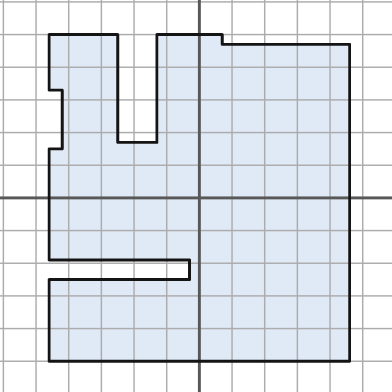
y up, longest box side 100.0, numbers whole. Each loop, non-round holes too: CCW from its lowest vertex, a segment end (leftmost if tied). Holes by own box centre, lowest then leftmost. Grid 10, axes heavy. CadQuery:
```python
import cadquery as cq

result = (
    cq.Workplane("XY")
    .moveTo(-46.0, -50.0)
    .lineTo(46.0, -50.0)
    .lineTo(46.0, 47.0)
    .lineTo(7.0, 47.0)
    .lineTo(7.0, 50.0)
    .lineTo(-13.0, 50.0)
    .lineTo(-13.0, 17.0)
    .lineTo(-25.0, 17.0)
    .lineTo(-25.0, 50.0)
    .lineTo(-46.0, 50.0)
    .lineTo(-46.0, 33.0)
    .lineTo(-42.0, 33.0)
    .lineTo(-42.0, 15.0)
    .lineTo(-46.0, 15.0)
    .lineTo(-46.0, -19.0)
    .lineTo(-3.0, -19.0)
    .lineTo(-3.0, -25.0)
    .lineTo(-46.0, -25.0)
    .close()
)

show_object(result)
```